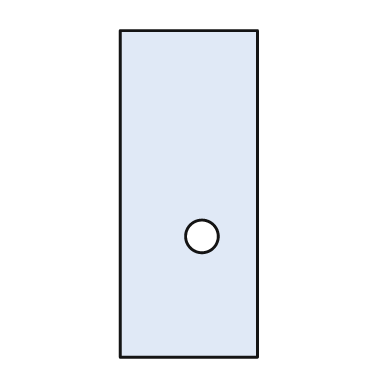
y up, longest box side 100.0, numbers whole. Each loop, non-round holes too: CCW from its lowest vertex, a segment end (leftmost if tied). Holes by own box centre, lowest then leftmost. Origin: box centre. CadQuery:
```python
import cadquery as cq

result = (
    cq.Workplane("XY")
    .moveTo(-21.0, -50.0)
    .lineTo(21.0, -50.0)
    .lineTo(21.0, 50.0)
    .lineTo(-21.0, 50.0)
    .close()
    .moveTo(4.0, -13.0)
    .circle(5.0)
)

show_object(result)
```